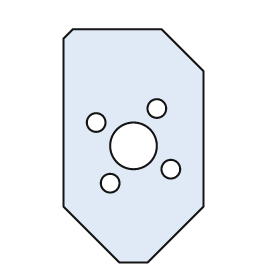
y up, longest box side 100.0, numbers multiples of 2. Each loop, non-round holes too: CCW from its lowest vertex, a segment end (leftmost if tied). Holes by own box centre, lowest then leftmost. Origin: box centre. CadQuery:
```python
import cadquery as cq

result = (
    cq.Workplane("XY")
    .moveTo(-6.0, -50.0)
    .lineTo(6.0, -50.0)
    .lineTo(30.0, -26.0)
    .lineTo(30.0, 32.0)
    .lineTo(12.0, 50.0)
    .lineTo(-26.0, 50.0)
    .lineTo(-30.0, 46.0)
    .lineTo(-30.0, -26.0)
    .close()
    .moveTo(-10.0, -16.0)
    .circle(4.0)
    .moveTo(16.0, -10.0)
    .circle(4.0)
    .moveTo(0.0, 0.0)
    .circle(10.0)
    .moveTo(-16.0, 10.0)
    .circle(4.0)
    .moveTo(10.0, 16.0)
    .circle(4.0)
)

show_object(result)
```